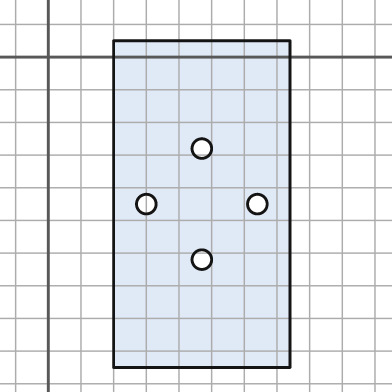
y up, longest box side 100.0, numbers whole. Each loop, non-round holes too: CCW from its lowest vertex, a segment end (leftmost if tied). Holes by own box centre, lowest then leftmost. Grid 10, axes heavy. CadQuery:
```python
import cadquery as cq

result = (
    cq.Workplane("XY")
    .moveTo(20.0, -95.0)
    .lineTo(74.0, -95.0)
    .lineTo(74.0, 5.0)
    .lineTo(20.0, 5.0)
    .close()
    .moveTo(47.0, -62.0)
    .circle(3.0)
    .moveTo(30.0, -45.0)
    .circle(3.0)
    .moveTo(64.0, -45.0)
    .circle(3.0)
    .moveTo(47.0, -28.0)
    .circle(3.0)
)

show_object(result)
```